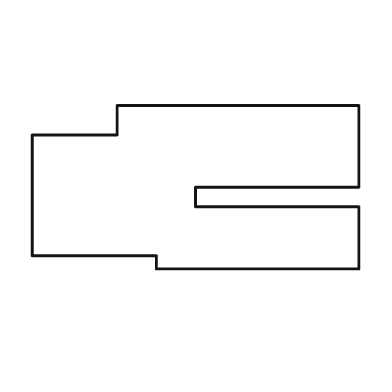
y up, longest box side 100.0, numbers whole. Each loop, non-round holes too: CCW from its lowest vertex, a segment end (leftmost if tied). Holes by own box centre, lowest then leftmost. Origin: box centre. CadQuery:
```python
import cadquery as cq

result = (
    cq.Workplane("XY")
    .moveTo(-12.0, -25.0)
    .lineTo(50.0, -25.0)
    .lineTo(50.0, -6.0)
    .lineTo(0.0, -6.0)
    .lineTo(0.0, 0.0)
    .lineTo(50.0, 0.0)
    .lineTo(50.0, 25.0)
    .lineTo(-24.0, 25.0)
    .lineTo(-24.0, 16.0)
    .lineTo(-50.0, 16.0)
    .lineTo(-50.0, -21.0)
    .lineTo(-12.0, -21.0)
    .close()
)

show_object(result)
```